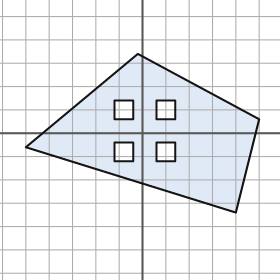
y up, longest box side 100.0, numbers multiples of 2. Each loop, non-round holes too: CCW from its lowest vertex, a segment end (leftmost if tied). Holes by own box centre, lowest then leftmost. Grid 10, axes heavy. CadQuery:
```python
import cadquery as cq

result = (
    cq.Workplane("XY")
    .moveTo(40.0, -34.0)
    .lineTo(50.0, 6.0)
    .lineTo(-2.0, 34.0)
    .lineTo(-50.0, -6.0)
    .close()
    .moveTo(-12.0, -12.0)
    .lineTo(-4.0, -12.0)
    .lineTo(-4.0, -4.0)
    .lineTo(-12.0, -4.0)
    .close()
    .moveTo(6.0, -12.0)
    .lineTo(14.0, -12.0)
    .lineTo(14.0, -4.0)
    .lineTo(6.0, -4.0)
    .close()
    .moveTo(-12.0, 6.0)
    .lineTo(-4.0, 6.0)
    .lineTo(-4.0, 14.0)
    .lineTo(-12.0, 14.0)
    .close()
    .moveTo(6.0, 6.0)
    .lineTo(14.0, 6.0)
    .lineTo(14.0, 14.0)
    .lineTo(6.0, 14.0)
    .close()
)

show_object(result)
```